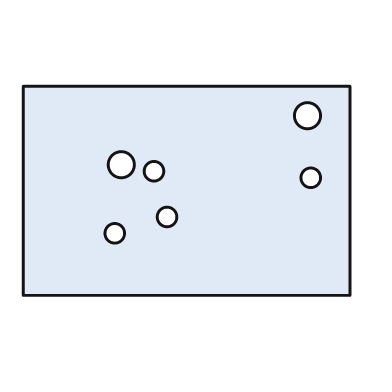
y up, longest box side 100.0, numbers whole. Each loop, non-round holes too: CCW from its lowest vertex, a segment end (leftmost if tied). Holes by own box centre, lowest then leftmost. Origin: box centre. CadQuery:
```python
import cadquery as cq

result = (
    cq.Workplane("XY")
    .moveTo(-50.0, -32.0)
    .lineTo(50.0, -32.0)
    .lineTo(50.0, 32.0)
    .lineTo(-50.0, 32.0)
    .close()
    .moveTo(-22.0, -13.0)
    .circle(3.0)
    .moveTo(-6.0, -8.0)
    .circle(3.0)
    .moveTo(38.0, 4.0)
    .circle(3.0)
    .moveTo(-10.0, 6.0)
    .circle(3.0)
    .moveTo(-20.0, 8.0)
    .circle(4.0)
    .moveTo(37.0, 23.0)
    .circle(4.0)
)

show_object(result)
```